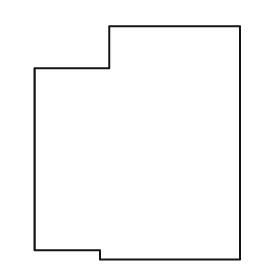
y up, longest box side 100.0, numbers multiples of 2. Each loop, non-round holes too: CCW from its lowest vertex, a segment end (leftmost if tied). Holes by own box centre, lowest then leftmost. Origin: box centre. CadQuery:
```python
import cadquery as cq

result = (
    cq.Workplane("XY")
    .moveTo(-16.0, -50.0)
    .lineTo(44.0, -50.0)
    .lineTo(44.0, 50.0)
    .lineTo(-12.0, 50.0)
    .lineTo(-12.0, 32.0)
    .lineTo(-44.0, 32.0)
    .lineTo(-44.0, -46.0)
    .lineTo(-16.0, -46.0)
    .close()
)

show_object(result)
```